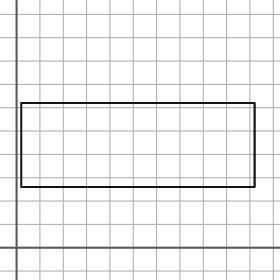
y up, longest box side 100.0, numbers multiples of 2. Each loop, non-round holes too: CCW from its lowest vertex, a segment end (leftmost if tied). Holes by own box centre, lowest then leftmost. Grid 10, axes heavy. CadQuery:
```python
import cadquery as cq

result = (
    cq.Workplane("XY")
    .moveTo(2.0, 26.0)
    .lineTo(102.0, 26.0)
    .lineTo(102.0, 62.0)
    .lineTo(2.0, 62.0)
    .close()
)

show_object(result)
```